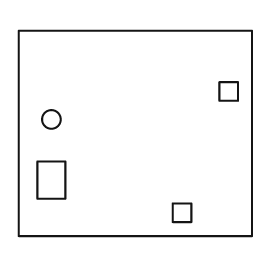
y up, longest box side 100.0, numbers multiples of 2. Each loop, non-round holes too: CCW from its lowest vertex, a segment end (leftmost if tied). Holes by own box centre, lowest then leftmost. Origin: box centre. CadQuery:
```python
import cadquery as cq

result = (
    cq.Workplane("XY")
    .moveTo(-50.0, -44.0)
    .lineTo(50.0, -44.0)
    .lineTo(50.0, 44.0)
    .lineTo(-50.0, 44.0)
    .close()
    .moveTo(16.0, -38.0)
    .lineTo(24.0, -38.0)
    .lineTo(24.0, -30.0)
    .lineTo(16.0, -30.0)
    .close()
    .moveTo(-42.0, -28.0)
    .lineTo(-30.0, -28.0)
    .lineTo(-30.0, -12.0)
    .lineTo(-42.0, -12.0)
    .close()
    .moveTo(-36.0, 6.0)
    .circle(4.0)
    .moveTo(36.0, 14.0)
    .lineTo(44.0, 14.0)
    .lineTo(44.0, 22.0)
    .lineTo(36.0, 22.0)
    .close()
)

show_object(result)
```